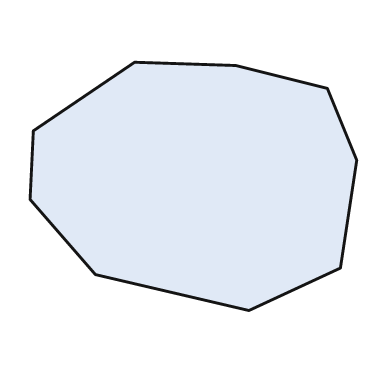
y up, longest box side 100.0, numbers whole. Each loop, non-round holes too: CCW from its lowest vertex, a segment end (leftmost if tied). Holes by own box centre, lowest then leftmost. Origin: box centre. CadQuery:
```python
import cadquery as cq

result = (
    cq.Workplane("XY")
    .moveTo(17.0, -38.0)
    .lineTo(45.0, -25.0)
    .lineTo(50.0, 8.0)
    .lineTo(41.0, 30.0)
    .lineTo(13.0, 37.0)
    .lineTo(-18.0, 38.0)
    .lineTo(-49.0, 17.0)
    .lineTo(-50.0, -4.0)
    .lineTo(-30.0, -27.0)
    .close()
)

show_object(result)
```